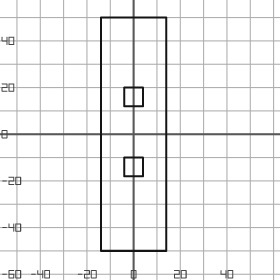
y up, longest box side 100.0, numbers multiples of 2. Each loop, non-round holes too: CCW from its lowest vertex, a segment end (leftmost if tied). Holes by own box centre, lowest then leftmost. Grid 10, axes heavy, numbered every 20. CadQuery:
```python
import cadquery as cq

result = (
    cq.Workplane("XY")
    .moveTo(-14.0, -50.0)
    .lineTo(14.0, -50.0)
    .lineTo(14.0, 50.0)
    .lineTo(-14.0, 50.0)
    .close()
    .moveTo(-4.0, -18.0)
    .lineTo(4.0, -18.0)
    .lineTo(4.0, -10.0)
    .lineTo(-4.0, -10.0)
    .close()
    .moveTo(-4.0, 12.0)
    .lineTo(4.0, 12.0)
    .lineTo(4.0, 20.0)
    .lineTo(-4.0, 20.0)
    .close()
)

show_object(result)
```